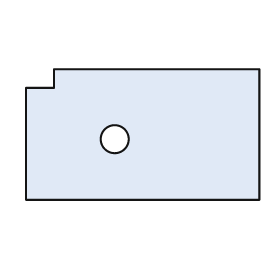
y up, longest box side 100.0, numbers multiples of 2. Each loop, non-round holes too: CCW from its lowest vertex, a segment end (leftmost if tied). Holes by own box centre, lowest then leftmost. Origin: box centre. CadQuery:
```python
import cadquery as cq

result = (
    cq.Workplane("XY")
    .moveTo(-50.0, -28.0)
    .lineTo(50.0, -28.0)
    .lineTo(50.0, 28.0)
    .lineTo(-38.0, 28.0)
    .lineTo(-38.0, 20.0)
    .lineTo(-50.0, 20.0)
    .close()
    .moveTo(-12.0, -2.0)
    .circle(6.0)
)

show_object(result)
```